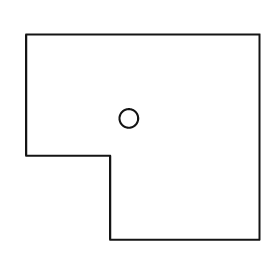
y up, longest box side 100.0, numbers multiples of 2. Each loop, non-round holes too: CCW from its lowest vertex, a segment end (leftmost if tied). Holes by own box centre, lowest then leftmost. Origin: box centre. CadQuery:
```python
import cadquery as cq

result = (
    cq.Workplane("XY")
    .moveTo(-14.0, -44.0)
    .lineTo(50.0, -44.0)
    .lineTo(50.0, 44.0)
    .lineTo(-50.0, 44.0)
    .lineTo(-50.0, -8.0)
    .lineTo(-14.0, -8.0)
    .close()
    .moveTo(-6.0, 8.0)
    .circle(4.0)
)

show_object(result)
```